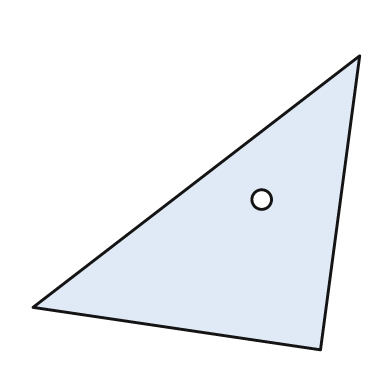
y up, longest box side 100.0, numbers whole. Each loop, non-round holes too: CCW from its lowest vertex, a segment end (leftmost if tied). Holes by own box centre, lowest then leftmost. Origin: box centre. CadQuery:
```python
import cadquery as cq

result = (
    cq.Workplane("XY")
    .moveTo(38.0, -45.0)
    .lineTo(50.0, 45.0)
    .lineTo(-50.0, -32.0)
    .close()
    .moveTo(20.0, 1.0)
    .circle(3.0)
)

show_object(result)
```